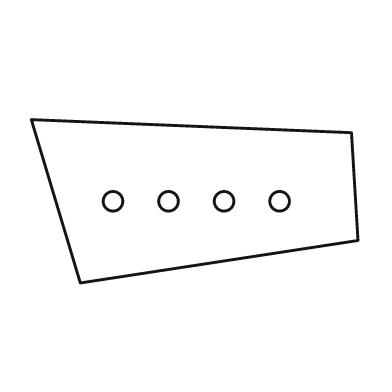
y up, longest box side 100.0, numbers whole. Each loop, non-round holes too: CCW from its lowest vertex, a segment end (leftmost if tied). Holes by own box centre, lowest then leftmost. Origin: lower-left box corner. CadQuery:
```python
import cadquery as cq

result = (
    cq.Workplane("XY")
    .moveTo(15.0, 0.0)
    .lineTo(100.0, 13.0)
    .lineTo(98.0, 46.0)
    .lineTo(0.0, 50.0)
    .close()
    .moveTo(25.0, 25.0)
    .circle(3.0)
    .moveTo(42.0, 25.0)
    .circle(3.0)
    .moveTo(59.0, 25.0)
    .circle(3.0)
    .moveTo(76.0, 25.0)
    .circle(3.0)
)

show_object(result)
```